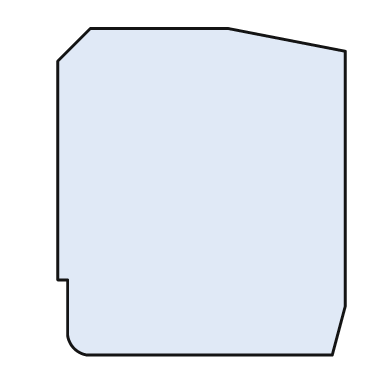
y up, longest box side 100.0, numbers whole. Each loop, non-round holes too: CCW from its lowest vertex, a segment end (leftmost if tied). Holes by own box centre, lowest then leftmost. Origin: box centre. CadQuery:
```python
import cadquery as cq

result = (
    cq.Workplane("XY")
    .moveTo(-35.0, -50.0)
    .lineTo(40.0, -50.0)
    .lineTo(44.0, -35.0)
    .lineTo(44.0, 43.0)
    .lineTo(8.0, 50.0)
    .lineTo(-34.0, 50.0)
    .lineTo(-44.0, 40.0)
    .lineTo(-44.0, -27.0)
    .lineTo(-41.0, -27.0)
    .lineTo(-41.0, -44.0)
    .threePointArc((-39.0, -48.0), (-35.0, -50.0))
    .close()
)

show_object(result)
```